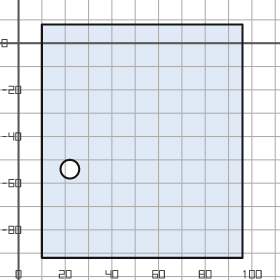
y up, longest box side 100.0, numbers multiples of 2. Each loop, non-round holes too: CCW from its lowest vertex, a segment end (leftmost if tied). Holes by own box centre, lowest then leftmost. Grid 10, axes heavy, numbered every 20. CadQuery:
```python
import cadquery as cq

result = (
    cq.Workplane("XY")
    .moveTo(10.0, -92.0)
    .lineTo(96.0, -92.0)
    .lineTo(96.0, 8.0)
    .lineTo(10.0, 8.0)
    .close()
    .moveTo(22.0, -54.0)
    .circle(4.0)
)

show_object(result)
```